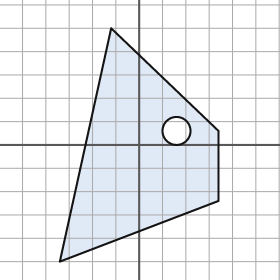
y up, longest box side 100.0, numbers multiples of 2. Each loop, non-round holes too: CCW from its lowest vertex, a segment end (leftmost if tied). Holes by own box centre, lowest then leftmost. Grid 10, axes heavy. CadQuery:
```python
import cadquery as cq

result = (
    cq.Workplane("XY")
    .moveTo(-34.0, -50.0)
    .lineTo(34.0, -24.0)
    .lineTo(34.0, 6.0)
    .lineTo(-12.0, 50.0)
    .close()
    .moveTo(16.0, 6.0)
    .circle(6.0)
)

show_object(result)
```